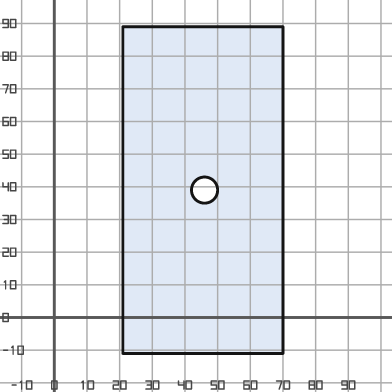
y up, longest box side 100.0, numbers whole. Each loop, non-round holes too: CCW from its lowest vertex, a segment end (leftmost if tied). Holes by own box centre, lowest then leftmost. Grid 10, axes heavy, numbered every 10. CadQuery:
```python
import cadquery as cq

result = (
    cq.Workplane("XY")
    .moveTo(21.0, -11.0)
    .lineTo(70.0, -11.0)
    .lineTo(70.0, 89.0)
    .lineTo(21.0, 89.0)
    .close()
    .moveTo(46.0, 39.0)
    .circle(4.0)
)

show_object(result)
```